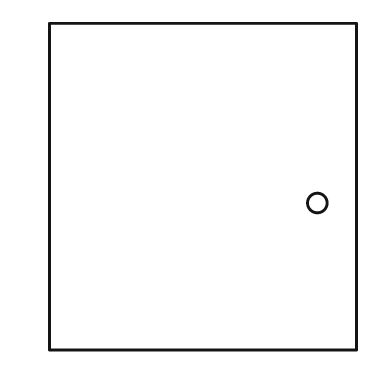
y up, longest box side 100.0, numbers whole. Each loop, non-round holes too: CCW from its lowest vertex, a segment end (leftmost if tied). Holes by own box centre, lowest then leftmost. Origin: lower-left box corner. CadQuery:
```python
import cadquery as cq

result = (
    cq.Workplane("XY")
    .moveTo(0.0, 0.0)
    .lineTo(94.0, 0.0)
    .lineTo(94.0, 100.0)
    .lineTo(0.0, 100.0)
    .close()
    .moveTo(82.0, 45.0)
    .circle(3.0)
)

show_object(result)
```